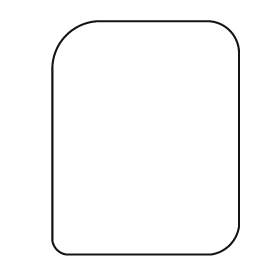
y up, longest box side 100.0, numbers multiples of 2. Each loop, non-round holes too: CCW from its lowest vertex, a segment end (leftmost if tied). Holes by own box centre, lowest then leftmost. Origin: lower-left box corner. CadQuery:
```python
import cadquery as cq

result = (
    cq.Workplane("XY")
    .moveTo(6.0, 0.0)
    .lineTo(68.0, 0.0)
    .threePointArc((76.0, 4.0), (80.0, 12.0))
    .lineTo(80.0, 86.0)
    .threePointArc((76.0, 96.0), (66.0, 100.0))
    .lineTo(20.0, 100.0)
    .threePointArc((6.0, 94.0), (0.0, 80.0))
    .lineTo(0.0, 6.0)
    .threePointArc((2.0, 2.0), (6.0, 0.0))
    .close()
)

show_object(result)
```